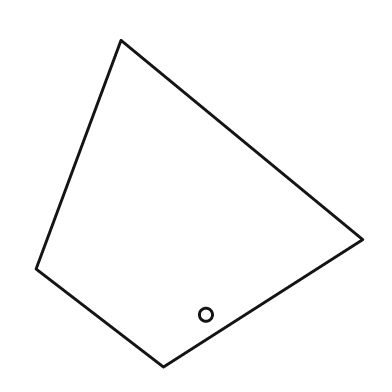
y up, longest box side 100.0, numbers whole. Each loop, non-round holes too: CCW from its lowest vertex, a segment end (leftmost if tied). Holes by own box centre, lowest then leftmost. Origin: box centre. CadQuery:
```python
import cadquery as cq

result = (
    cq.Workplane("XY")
    .moveTo(-11.0, -50.0)
    .lineTo(50.0, -11.0)
    .lineTo(-24.0, 50.0)
    .lineTo(-50.0, -20.0)
    .close()
    .moveTo(2.0, -34.0)
    .circle(2.0)
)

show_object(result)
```